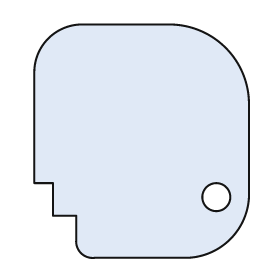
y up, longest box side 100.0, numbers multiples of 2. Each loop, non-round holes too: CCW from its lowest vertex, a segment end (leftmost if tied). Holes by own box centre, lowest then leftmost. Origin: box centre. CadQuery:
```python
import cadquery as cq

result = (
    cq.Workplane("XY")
    .moveTo(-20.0, -50.0)
    .lineTo(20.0, -50.0)
    .threePointArc((38.0, -42.0), (46.0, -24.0))
    .lineTo(46.0, 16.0)
    .threePointArc((36.0, 40.0), (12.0, 50.0))
    .lineTo(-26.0, 50.0)
    .threePointArc((-40.0, 44.0), (-46.0, 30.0))
    .lineTo(-46.0, -18.0)
    .lineTo(-38.0, -18.0)
    .lineTo(-38.0, -32.0)
    .lineTo(-28.0, -32.0)
    .lineTo(-28.0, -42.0)
    .threePointArc((-26.0, -48.0), (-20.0, -50.0))
    .close()
    .moveTo(32.0, -24.0)
    .circle(6.0)
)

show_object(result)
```